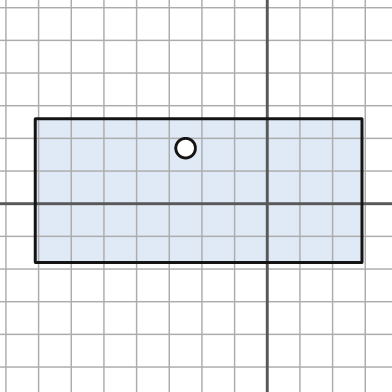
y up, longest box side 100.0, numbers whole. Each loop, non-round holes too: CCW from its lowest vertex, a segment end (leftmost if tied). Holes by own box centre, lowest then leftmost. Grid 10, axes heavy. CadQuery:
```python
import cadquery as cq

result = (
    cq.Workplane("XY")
    .moveTo(-71.0, -18.0)
    .lineTo(29.0, -18.0)
    .lineTo(29.0, 26.0)
    .lineTo(-71.0, 26.0)
    .close()
    .moveTo(-25.0, 17.0)
    .circle(3.0)
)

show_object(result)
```